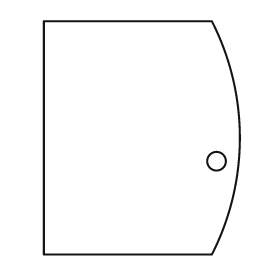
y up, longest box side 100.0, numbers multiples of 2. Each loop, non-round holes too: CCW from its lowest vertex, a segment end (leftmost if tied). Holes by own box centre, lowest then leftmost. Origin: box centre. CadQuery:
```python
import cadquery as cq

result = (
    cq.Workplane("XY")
    .moveTo(-42.0, -50.0)
    .lineTo(30.0, -50.0)
    .threePointArc((42.0, 0.0), (30.0, 50.0))
    .lineTo(-42.0, 50.0)
    .close()
    .moveTo(32.0, -10.0)
    .circle(4.0)
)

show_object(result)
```